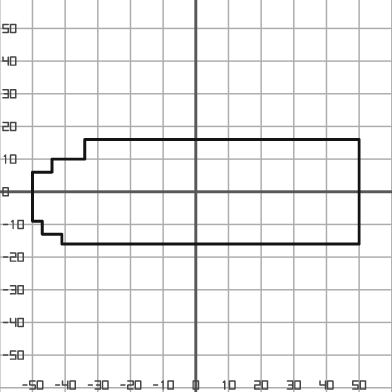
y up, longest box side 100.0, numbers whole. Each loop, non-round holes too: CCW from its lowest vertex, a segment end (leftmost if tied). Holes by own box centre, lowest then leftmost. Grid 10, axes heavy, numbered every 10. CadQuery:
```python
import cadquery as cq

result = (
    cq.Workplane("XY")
    .moveTo(-41.0, -16.0)
    .lineTo(50.0, -16.0)
    .lineTo(50.0, 16.0)
    .lineTo(-34.0, 16.0)
    .lineTo(-34.0, 10.0)
    .lineTo(-44.0, 10.0)
    .lineTo(-44.0, 6.0)
    .lineTo(-50.0, 6.0)
    .lineTo(-50.0, -9.0)
    .lineTo(-47.0, -9.0)
    .lineTo(-47.0, -13.0)
    .lineTo(-41.0, -13.0)
    .close()
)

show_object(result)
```